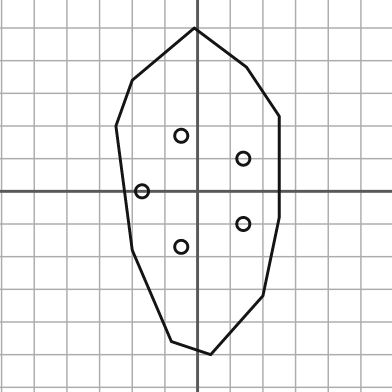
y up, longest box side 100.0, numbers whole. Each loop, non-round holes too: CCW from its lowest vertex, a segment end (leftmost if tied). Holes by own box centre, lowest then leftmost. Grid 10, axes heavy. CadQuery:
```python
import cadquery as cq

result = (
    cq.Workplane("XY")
    .moveTo(4.0, -50.0)
    .lineTo(20.0, -32.0)
    .lineTo(25.0, -8.0)
    .lineTo(25.0, 23.0)
    .lineTo(15.0, 38.0)
    .lineTo(-1.0, 50.0)
    .lineTo(-20.0, 34.0)
    .lineTo(-25.0, 20.0)
    .lineTo(-20.0, -18.0)
    .lineTo(-8.0, -46.0)
    .close()
    .moveTo(-5.0, -17.0)
    .circle(2.0)
    .moveTo(14.0, -10.0)
    .circle(2.0)
    .moveTo(-17.0, 0.0)
    .circle(2.0)
    .moveTo(14.0, 10.0)
    .circle(2.0)
    .moveTo(-5.0, 17.0)
    .circle(2.0)
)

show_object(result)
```